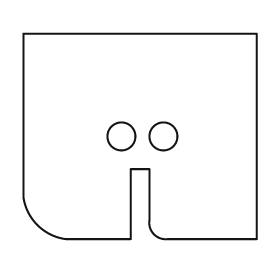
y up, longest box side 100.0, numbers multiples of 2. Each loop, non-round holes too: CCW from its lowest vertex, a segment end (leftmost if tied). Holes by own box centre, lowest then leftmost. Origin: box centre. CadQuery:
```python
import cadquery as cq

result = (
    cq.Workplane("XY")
    .moveTo(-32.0, -44.0)
    .lineTo(-4.0, -44.0)
    .lineTo(-4.0, -14.0)
    .lineTo(4.0, -14.0)
    .lineTo(4.0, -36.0)
    .threePointArc((6.0, -42.0), (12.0, -44.0))
    .lineTo(50.0, -44.0)
    .lineTo(50.0, 44.0)
    .lineTo(-50.0, 44.0)
    .lineTo(-50.0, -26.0)
    .threePointArc((-44.0, -38.0), (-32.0, -44.0))
    .close()
    .moveTo(-8.0, 0.0)
    .circle(6.0)
    .moveTo(10.0, 0.0)
    .circle(6.0)
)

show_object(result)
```